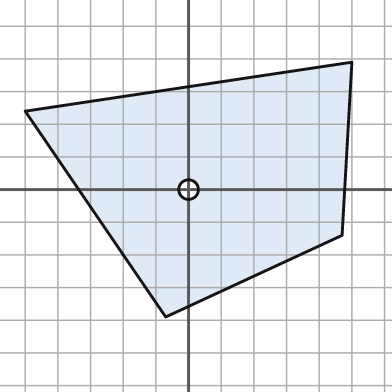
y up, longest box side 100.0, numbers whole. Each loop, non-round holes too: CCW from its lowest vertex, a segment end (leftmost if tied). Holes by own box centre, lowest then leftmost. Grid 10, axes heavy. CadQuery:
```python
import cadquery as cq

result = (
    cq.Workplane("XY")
    .moveTo(-7.0, -39.0)
    .lineTo(47.0, -14.0)
    .lineTo(50.0, 39.0)
    .lineTo(-50.0, 24.0)
    .close()
    .moveTo(0.0, 0.0)
    .circle(3.0)
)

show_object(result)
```